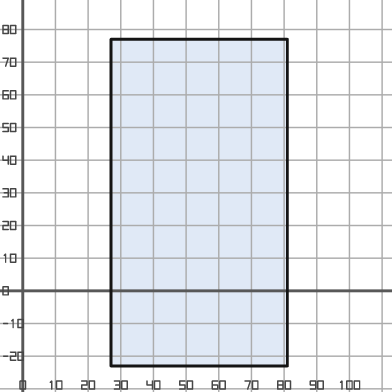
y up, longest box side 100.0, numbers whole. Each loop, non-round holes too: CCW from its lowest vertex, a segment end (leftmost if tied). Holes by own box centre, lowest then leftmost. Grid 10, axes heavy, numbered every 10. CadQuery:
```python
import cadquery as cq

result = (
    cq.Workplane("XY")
    .moveTo(27.0, -23.0)
    .lineTo(81.0, -23.0)
    .lineTo(81.0, 77.0)
    .lineTo(27.0, 77.0)
    .close()
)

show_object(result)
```